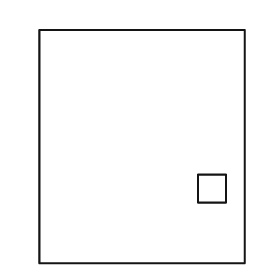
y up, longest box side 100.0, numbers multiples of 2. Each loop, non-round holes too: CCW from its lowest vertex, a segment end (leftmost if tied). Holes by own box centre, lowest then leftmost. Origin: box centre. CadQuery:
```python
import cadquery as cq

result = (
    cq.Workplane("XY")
    .moveTo(-44.0, -50.0)
    .lineTo(44.0, -50.0)
    .lineTo(44.0, 50.0)
    .lineTo(-44.0, 50.0)
    .close()
    .moveTo(24.0, -24.0)
    .lineTo(36.0, -24.0)
    .lineTo(36.0, -12.0)
    .lineTo(24.0, -12.0)
    .close()
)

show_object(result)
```